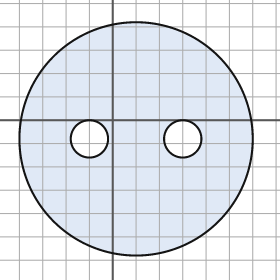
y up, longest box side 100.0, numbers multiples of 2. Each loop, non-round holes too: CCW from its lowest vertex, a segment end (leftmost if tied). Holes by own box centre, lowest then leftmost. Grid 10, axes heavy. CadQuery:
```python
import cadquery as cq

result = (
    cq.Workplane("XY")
    .moveTo(10.0, -8.0)
    .circle(50.0)
    .moveTo(-10.0, -8.0)
    .circle(8.0)
    .moveTo(30.0, -8.0)
    .circle(8.0)
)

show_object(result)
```